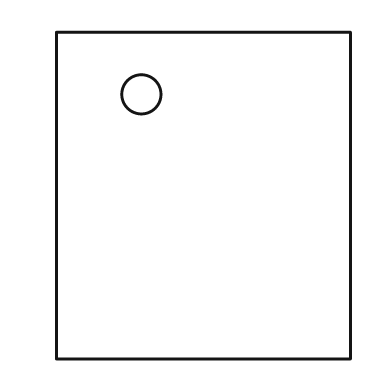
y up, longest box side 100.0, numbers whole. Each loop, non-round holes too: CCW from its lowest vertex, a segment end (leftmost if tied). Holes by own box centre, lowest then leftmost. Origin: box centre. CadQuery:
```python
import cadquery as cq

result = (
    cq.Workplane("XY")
    .moveTo(-45.0, -50.0)
    .lineTo(45.0, -50.0)
    .lineTo(45.0, 50.0)
    .lineTo(-45.0, 50.0)
    .close()
    .moveTo(-19.0, 31.0)
    .circle(6.0)
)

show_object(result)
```